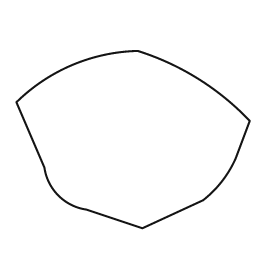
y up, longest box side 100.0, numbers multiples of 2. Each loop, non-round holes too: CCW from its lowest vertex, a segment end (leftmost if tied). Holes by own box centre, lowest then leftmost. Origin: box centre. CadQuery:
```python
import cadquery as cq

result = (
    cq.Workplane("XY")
    .moveTo(4.0, -38.0)
    .lineTo(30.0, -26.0)
    .threePointArc((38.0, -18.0), (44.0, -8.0))
    .lineTo(50.0, 8.0)
    .threePointArc((28.0, 26.0), (2.0, 38.0))
    .threePointArc((-26.0, 32.0), (-50.0, 16.0))
    .lineTo(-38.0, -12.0)
    .threePointArc((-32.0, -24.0), (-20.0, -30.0))
    .close()
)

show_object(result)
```